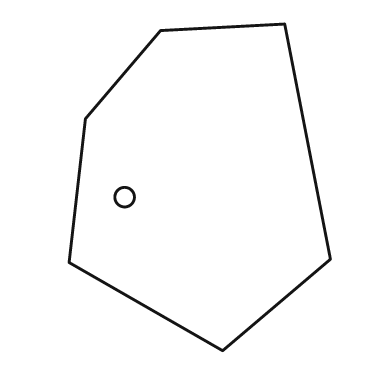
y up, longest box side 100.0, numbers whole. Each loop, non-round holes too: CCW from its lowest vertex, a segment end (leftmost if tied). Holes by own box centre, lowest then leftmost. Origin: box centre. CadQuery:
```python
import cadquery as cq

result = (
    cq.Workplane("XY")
    .moveTo(7.0, -50.0)
    .lineTo(40.0, -22.0)
    .lineTo(26.0, 50.0)
    .lineTo(-12.0, 48.0)
    .lineTo(-35.0, 21.0)
    .lineTo(-40.0, -23.0)
    .close()
    .moveTo(-23.0, -3.0)
    .circle(3.0)
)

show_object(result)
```